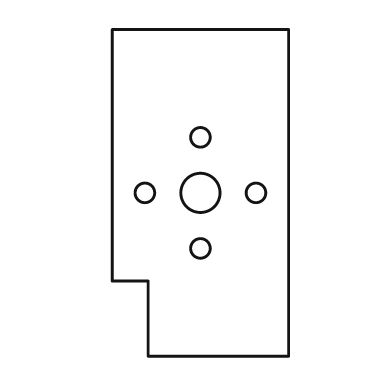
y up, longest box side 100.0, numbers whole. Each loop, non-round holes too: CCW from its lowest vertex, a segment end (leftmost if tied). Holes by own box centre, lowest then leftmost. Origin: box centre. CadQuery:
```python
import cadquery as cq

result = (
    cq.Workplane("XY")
    .moveTo(-16.0, -50.0)
    .lineTo(27.0, -50.0)
    .lineTo(27.0, 50.0)
    .lineTo(-27.0, 50.0)
    .lineTo(-27.0, -27.0)
    .lineTo(-16.0, -27.0)
    .close()
    .moveTo(0.0, -17.0)
    .circle(3.0)
    .moveTo(-17.0, 0.0)
    .circle(3.0)
    .moveTo(0.0, 0.0)
    .circle(6.0)
    .moveTo(17.0, 0.0)
    .circle(3.0)
    .moveTo(0.0, 17.0)
    .circle(3.0)
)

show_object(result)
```